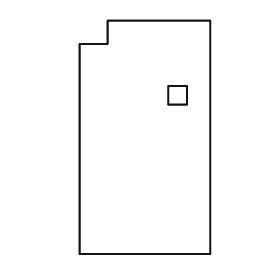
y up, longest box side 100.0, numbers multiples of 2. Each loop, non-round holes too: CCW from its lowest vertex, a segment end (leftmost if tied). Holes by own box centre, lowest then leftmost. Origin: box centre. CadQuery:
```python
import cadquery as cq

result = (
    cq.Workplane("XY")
    .moveTo(-28.0, -50.0)
    .lineTo(28.0, -50.0)
    .lineTo(28.0, 50.0)
    .lineTo(-16.0, 50.0)
    .lineTo(-16.0, 40.0)
    .lineTo(-28.0, 40.0)
    .close()
    .moveTo(10.0, 14.0)
    .lineTo(18.0, 14.0)
    .lineTo(18.0, 22.0)
    .lineTo(10.0, 22.0)
    .close()
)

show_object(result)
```